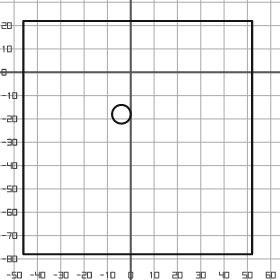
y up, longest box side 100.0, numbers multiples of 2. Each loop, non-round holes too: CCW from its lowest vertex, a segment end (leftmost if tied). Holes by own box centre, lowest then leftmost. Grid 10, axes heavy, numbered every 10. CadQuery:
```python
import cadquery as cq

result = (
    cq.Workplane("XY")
    .moveTo(-46.0, -78.0)
    .lineTo(52.0, -78.0)
    .lineTo(52.0, 22.0)
    .lineTo(-46.0, 22.0)
    .close()
    .moveTo(-4.0, -18.0)
    .circle(4.0)
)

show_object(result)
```